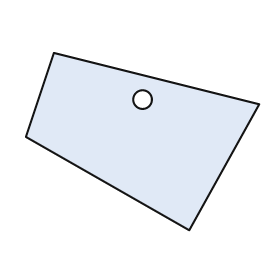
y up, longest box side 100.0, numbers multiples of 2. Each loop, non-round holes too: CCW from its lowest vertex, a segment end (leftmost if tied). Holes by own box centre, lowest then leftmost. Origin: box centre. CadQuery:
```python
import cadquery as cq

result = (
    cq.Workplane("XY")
    .moveTo(20.0, -38.0)
    .lineTo(50.0, 16.0)
    .lineTo(-38.0, 38.0)
    .lineTo(-50.0, 2.0)
    .close()
    .moveTo(0.0, 18.0)
    .circle(4.0)
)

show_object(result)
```